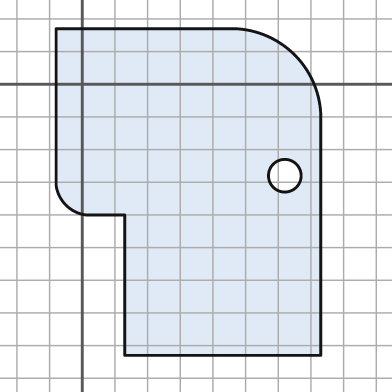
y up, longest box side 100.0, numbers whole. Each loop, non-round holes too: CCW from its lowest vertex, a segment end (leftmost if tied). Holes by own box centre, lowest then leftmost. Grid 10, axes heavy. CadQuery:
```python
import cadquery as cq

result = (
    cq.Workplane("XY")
    .moveTo(13.0, -83.0)
    .lineTo(73.0, -83.0)
    .lineTo(73.0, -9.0)
    .threePointArc((65.0, 9.0), (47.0, 17.0))
    .lineTo(-8.0, 17.0)
    .lineTo(-8.0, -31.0)
    .threePointArc((-5.0, -37.0), (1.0, -40.0))
    .lineTo(13.0, -40.0)
    .close()
    .moveTo(62.0, -28.0)
    .circle(5.0)
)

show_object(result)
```